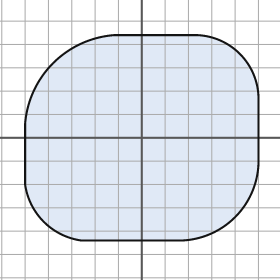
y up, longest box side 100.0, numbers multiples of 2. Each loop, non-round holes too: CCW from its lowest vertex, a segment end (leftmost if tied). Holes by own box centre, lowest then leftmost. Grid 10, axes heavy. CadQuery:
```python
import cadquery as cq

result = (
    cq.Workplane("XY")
    .moveTo(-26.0, -44.0)
    .lineTo(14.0, -44.0)
    .threePointArc((40.0, -34.0), (50.0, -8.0))
    .lineTo(50.0, 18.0)
    .threePointArc((42.0, 36.0), (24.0, 44.0))
    .lineTo(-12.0, 44.0)
    .threePointArc((-38.0, 32.0), (-50.0, 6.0))
    .lineTo(-50.0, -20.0)
    .threePointArc((-42.0, -36.0), (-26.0, -44.0))
    .close()
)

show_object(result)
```